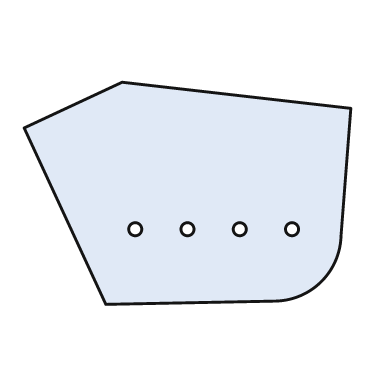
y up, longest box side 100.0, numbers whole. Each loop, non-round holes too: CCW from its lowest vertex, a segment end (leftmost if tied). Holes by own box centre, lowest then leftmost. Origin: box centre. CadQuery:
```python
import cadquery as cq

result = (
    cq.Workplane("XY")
    .moveTo(-25.0, -34.0)
    .lineTo(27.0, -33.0)
    .threePointArc((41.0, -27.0), (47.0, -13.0))
    .lineTo(50.0, 26.0)
    .lineTo(-20.0, 34.0)
    .lineTo(-50.0, 20.0)
    .close()
    .moveTo(-16.0, -11.0)
    .circle(2.0)
    .moveTo(0.0, -11.0)
    .circle(2.0)
    .moveTo(16.0, -11.0)
    .circle(2.0)
    .moveTo(32.0, -11.0)
    .circle(2.0)
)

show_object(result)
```